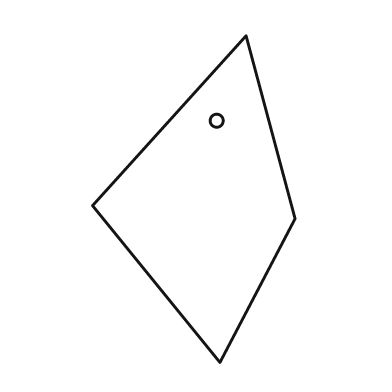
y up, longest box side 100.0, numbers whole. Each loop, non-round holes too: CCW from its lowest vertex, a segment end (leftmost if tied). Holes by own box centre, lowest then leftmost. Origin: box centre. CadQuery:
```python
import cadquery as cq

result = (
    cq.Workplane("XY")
    .moveTo(8.0, -50.0)
    .lineTo(31.0, -6.0)
    .lineTo(16.0, 50.0)
    .lineTo(-31.0, -2.0)
    .close()
    .moveTo(7.0, 24.0)
    .circle(2.0)
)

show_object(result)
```